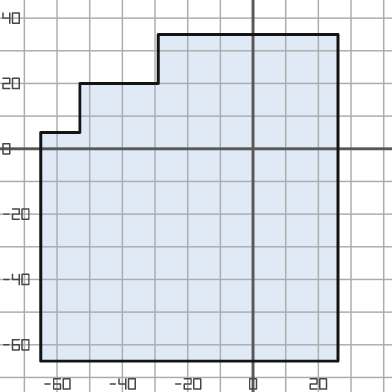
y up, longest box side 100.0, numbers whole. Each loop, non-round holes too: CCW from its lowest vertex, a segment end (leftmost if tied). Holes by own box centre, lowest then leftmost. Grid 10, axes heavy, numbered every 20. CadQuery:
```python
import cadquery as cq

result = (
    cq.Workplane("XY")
    .moveTo(-65.0, -65.0)
    .lineTo(26.0, -65.0)
    .lineTo(26.0, 35.0)
    .lineTo(-29.0, 35.0)
    .lineTo(-29.0, 20.0)
    .lineTo(-53.0, 20.0)
    .lineTo(-53.0, 5.0)
    .lineTo(-65.0, 5.0)
    .close()
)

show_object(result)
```